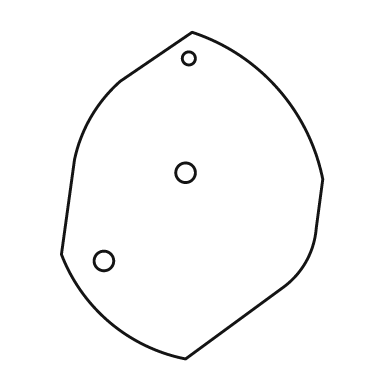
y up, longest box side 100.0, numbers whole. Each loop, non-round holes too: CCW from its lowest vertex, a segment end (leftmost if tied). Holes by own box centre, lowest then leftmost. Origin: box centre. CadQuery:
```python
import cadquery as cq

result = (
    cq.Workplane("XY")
    .moveTo(-2.0, -50.0)
    .lineTo(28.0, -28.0)
    .threePointArc((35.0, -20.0), (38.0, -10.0))
    .lineTo(40.0, 5.0)
    .threePointArc((26.0, 33.0), (0.0, 50.0))
    .lineTo(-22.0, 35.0)
    .threePointArc((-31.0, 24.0), (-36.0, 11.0))
    .lineTo(-40.0, -18.0)
    .threePointArc((-25.0, -39.0), (-2.0, -50.0))
    .close()
    .moveTo(-27.0, -20.0)
    .circle(3.0)
    .moveTo(-2.0, 7.0)
    .circle(3.0)
    .moveTo(-1.0, 42.0)
    .circle(2.0)
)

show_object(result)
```